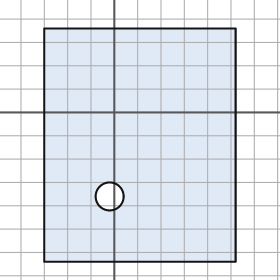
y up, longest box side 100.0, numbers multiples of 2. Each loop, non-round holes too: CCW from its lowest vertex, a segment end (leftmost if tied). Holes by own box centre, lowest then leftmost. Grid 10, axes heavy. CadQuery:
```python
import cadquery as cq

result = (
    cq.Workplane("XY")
    .moveTo(-30.0, -64.0)
    .lineTo(52.0, -64.0)
    .lineTo(52.0, 36.0)
    .lineTo(-30.0, 36.0)
    .close()
    .moveTo(-2.0, -36.0)
    .circle(6.0)
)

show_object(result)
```